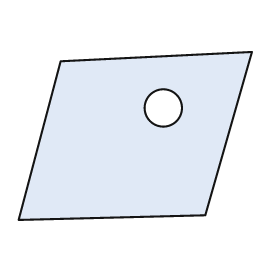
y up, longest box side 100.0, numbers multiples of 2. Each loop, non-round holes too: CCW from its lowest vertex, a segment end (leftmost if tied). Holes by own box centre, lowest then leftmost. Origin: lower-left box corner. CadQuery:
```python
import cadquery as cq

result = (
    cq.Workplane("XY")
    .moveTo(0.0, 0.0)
    .lineTo(80.0, 2.0)
    .lineTo(100.0, 72.0)
    .lineTo(18.0, 68.0)
    .close()
    .moveTo(62.0, 48.0)
    .circle(8.0)
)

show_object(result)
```